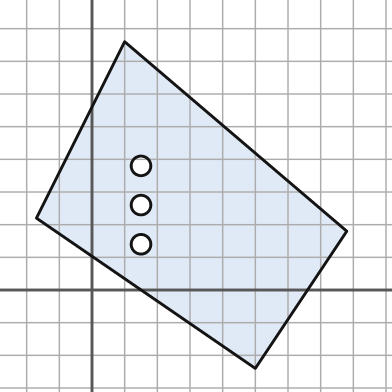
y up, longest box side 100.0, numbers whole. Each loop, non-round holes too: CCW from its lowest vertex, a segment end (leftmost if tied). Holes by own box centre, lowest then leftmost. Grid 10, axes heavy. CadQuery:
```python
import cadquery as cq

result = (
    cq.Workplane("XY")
    .moveTo(50.0, -24.0)
    .lineTo(78.0, 18.0)
    .lineTo(10.0, 76.0)
    .lineTo(-17.0, 22.0)
    .close()
    .moveTo(15.0, 14.0)
    .circle(3.0)
    .moveTo(15.0, 26.0)
    .circle(3.0)
    .moveTo(15.0, 38.0)
    .circle(3.0)
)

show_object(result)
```